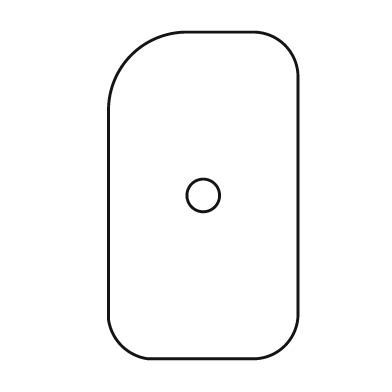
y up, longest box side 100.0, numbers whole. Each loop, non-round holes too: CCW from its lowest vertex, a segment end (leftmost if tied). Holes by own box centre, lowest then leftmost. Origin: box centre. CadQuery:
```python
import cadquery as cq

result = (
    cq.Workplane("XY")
    .moveTo(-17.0, -50.0)
    .lineTo(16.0, -50.0)
    .threePointArc((25.0, -46.0), (29.0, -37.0))
    .lineTo(29.0, 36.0)
    .threePointArc((25.0, 46.0), (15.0, 50.0))
    .lineTo(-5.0, 50.0)
    .threePointArc((-22.0, 43.0), (-29.0, 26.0))
    .lineTo(-29.0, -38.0)
    .threePointArc((-25.0, -46.0), (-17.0, -50.0))
    .close()
    .moveTo(0.0, 0.0)
    .circle(5.0)
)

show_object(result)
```